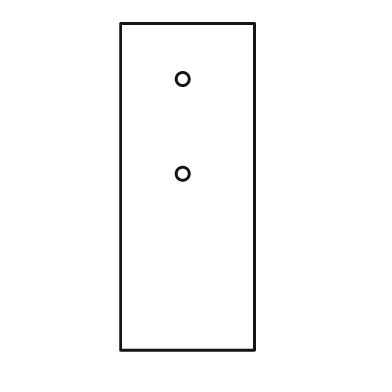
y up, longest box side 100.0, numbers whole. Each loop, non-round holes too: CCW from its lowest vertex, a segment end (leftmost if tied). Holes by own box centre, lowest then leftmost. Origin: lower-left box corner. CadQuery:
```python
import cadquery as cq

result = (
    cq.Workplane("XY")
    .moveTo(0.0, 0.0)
    .lineTo(41.0, 0.0)
    .lineTo(41.0, 100.0)
    .lineTo(0.0, 100.0)
    .close()
    .moveTo(19.0, 54.0)
    .circle(2.0)
    .moveTo(19.0, 83.0)
    .circle(2.0)
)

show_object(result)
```